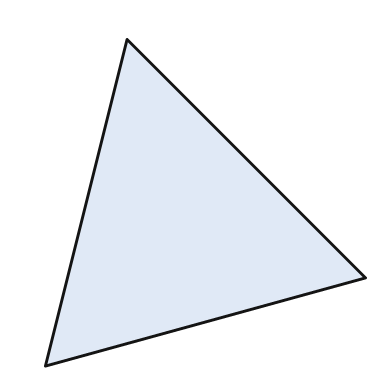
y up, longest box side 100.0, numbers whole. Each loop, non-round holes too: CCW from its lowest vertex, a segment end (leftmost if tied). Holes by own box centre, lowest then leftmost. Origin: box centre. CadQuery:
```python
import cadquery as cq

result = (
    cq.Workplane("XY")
    .moveTo(-49.0, -50.0)
    .lineTo(49.0, -23.0)
    .lineTo(-24.0, 50.0)
    .close()
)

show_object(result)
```